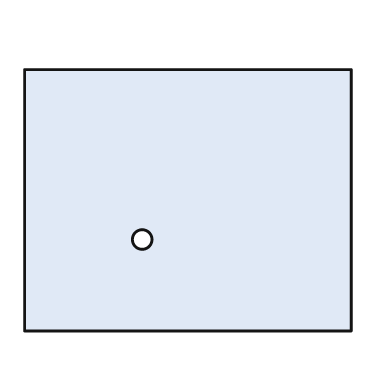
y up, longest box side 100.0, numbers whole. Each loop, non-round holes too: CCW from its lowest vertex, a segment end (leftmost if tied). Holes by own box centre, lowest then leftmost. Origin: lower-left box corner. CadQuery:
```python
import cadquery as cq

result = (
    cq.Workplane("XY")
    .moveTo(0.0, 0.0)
    .lineTo(100.0, 0.0)
    .lineTo(100.0, 80.0)
    .lineTo(0.0, 80.0)
    .close()
    .moveTo(36.0, 28.0)
    .circle(3.0)
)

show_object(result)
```